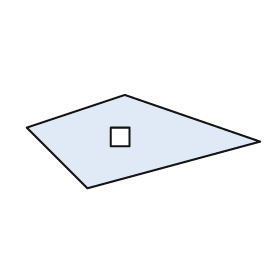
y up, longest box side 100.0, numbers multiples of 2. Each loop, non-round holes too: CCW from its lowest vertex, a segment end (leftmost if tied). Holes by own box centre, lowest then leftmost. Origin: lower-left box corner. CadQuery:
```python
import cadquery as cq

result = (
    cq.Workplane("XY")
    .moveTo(26.0, 0.0)
    .lineTo(100.0, 20.0)
    .lineTo(42.0, 40.0)
    .lineTo(0.0, 26.0)
    .close()
    .moveTo(36.0, 18.0)
    .lineTo(44.0, 18.0)
    .lineTo(44.0, 26.0)
    .lineTo(36.0, 26.0)
    .close()
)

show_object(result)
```